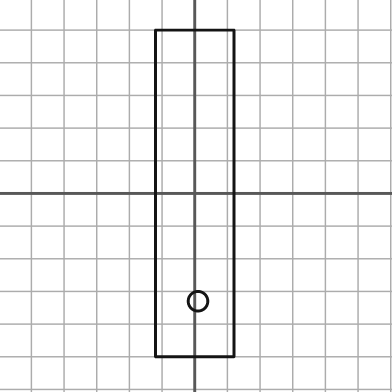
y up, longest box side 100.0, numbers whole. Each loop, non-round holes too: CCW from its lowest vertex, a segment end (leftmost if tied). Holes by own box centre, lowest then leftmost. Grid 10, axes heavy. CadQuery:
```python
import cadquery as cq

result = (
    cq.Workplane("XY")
    .moveTo(-12.0, -50.0)
    .lineTo(12.0, -50.0)
    .lineTo(12.0, 50.0)
    .lineTo(-12.0, 50.0)
    .close()
    .moveTo(1.0, -33.0)
    .circle(3.0)
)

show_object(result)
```